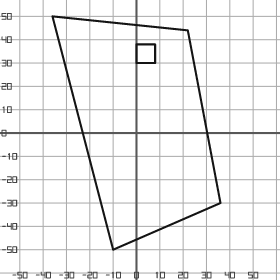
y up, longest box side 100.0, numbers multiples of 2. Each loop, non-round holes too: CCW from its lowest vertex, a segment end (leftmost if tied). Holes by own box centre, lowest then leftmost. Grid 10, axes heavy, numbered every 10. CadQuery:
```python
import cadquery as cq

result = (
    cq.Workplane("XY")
    .moveTo(-10.0, -50.0)
    .lineTo(36.0, -30.0)
    .lineTo(22.0, 44.0)
    .lineTo(-36.0, 50.0)
    .close()
    .moveTo(0.0, 30.0)
    .lineTo(8.0, 30.0)
    .lineTo(8.0, 38.0)
    .lineTo(0.0, 38.0)
    .close()
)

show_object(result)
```